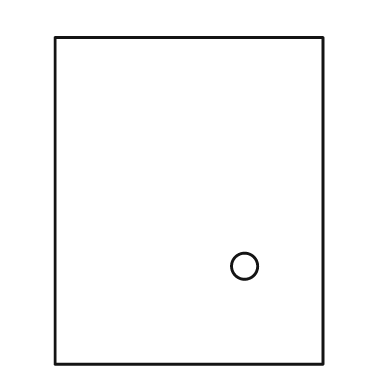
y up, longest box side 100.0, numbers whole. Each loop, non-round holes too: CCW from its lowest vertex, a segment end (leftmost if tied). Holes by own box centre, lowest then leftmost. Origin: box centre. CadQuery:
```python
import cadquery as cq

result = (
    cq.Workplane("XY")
    .moveTo(-41.0, -50.0)
    .lineTo(41.0, -50.0)
    .lineTo(41.0, 50.0)
    .lineTo(-41.0, 50.0)
    .close()
    .moveTo(17.0, -20.0)
    .circle(4.0)
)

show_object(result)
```